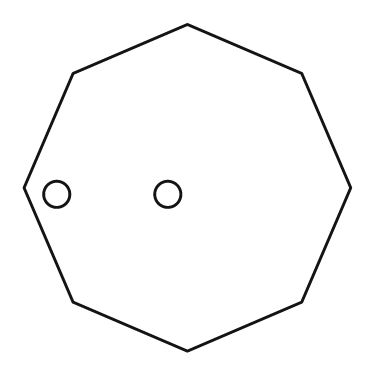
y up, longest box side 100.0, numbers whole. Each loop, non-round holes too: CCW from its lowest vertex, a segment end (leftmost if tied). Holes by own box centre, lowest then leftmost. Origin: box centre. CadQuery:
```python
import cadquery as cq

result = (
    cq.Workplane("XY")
    .moveTo(0.0, -50.0)
    .lineTo(35.0, -35.0)
    .lineTo(50.0, 0.0)
    .lineTo(35.0, 35.0)
    .lineTo(0.0, 50.0)
    .lineTo(-35.0, 35.0)
    .lineTo(-50.0, 0.0)
    .lineTo(-35.0, -35.0)
    .close()
    .moveTo(-40.0, -2.0)
    .circle(4.0)
    .moveTo(-6.0, -2.0)
    .circle(4.0)
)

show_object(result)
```